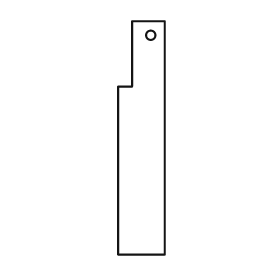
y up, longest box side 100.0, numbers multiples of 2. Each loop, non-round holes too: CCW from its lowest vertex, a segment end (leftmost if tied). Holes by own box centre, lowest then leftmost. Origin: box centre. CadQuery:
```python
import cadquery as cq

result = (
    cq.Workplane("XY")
    .moveTo(-10.0, -50.0)
    .lineTo(10.0, -50.0)
    .lineTo(10.0, 50.0)
    .lineTo(-4.0, 50.0)
    .lineTo(-4.0, 22.0)
    .lineTo(-10.0, 22.0)
    .close()
    .moveTo(4.0, 44.0)
    .circle(2.0)
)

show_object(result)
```